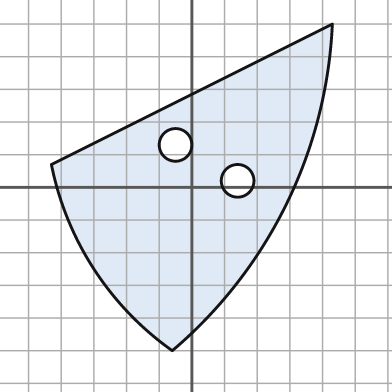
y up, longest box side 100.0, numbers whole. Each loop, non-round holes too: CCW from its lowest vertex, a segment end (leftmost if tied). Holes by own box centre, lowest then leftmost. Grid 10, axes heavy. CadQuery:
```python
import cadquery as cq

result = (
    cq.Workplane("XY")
    .moveTo(-6.0, -50.0)
    .threePointArc((29.0, -5.0), (43.0, 50.0))
    .lineTo(-43.0, 7.0)
    .threePointArc((-30.0, -25.0), (-6.0, -50.0))
    .close()
    .moveTo(14.0, 2.0)
    .circle(5.0)
    .moveTo(-5.0, 13.0)
    .circle(5.0)
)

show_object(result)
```